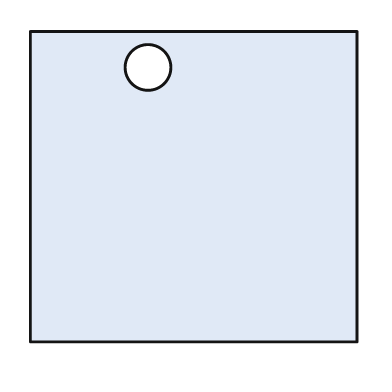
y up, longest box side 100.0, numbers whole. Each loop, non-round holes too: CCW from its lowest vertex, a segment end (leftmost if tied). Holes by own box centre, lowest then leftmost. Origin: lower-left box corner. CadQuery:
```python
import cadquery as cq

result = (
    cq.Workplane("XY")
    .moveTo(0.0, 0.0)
    .lineTo(100.0, 0.0)
    .lineTo(100.0, 95.0)
    .lineTo(0.0, 95.0)
    .close()
    .moveTo(36.0, 84.0)
    .circle(7.0)
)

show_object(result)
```